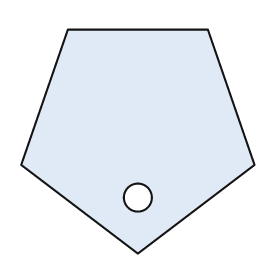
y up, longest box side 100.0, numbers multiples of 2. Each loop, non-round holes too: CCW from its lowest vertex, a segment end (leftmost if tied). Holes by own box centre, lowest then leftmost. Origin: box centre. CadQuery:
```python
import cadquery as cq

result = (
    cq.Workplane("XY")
    .moveTo(0.0, -48.0)
    .lineTo(50.0, -10.0)
    .lineTo(30.0, 48.0)
    .lineTo(-30.0, 48.0)
    .lineTo(-50.0, -10.0)
    .close()
    .moveTo(0.0, -24.0)
    .circle(6.0)
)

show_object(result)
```